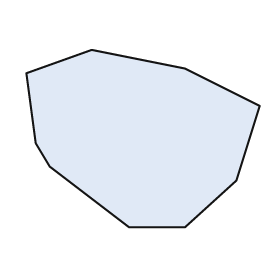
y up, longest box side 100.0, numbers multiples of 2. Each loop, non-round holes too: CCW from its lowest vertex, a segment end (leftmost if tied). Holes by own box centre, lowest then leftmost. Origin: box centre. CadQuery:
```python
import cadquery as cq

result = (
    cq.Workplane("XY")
    .moveTo(-6.0, -38.0)
    .lineTo(18.0, -38.0)
    .lineTo(40.0, -18.0)
    .lineTo(50.0, 14.0)
    .lineTo(18.0, 30.0)
    .lineTo(-22.0, 38.0)
    .lineTo(-50.0, 28.0)
    .lineTo(-46.0, -2.0)
    .lineTo(-40.0, -12.0)
    .close()
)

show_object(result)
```